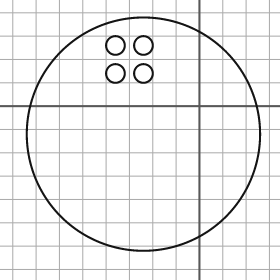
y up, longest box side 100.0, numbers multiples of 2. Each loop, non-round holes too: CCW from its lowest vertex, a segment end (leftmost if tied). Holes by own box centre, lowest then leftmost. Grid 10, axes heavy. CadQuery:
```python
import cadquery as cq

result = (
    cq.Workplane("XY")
    .moveTo(-24.0, -12.0)
    .circle(50.0)
    .moveTo(-36.0, 14.0)
    .circle(4.0)
    .moveTo(-24.0, 14.0)
    .circle(4.0)
    .moveTo(-36.0, 26.0)
    .circle(4.0)
    .moveTo(-24.0, 26.0)
    .circle(4.0)
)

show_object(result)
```